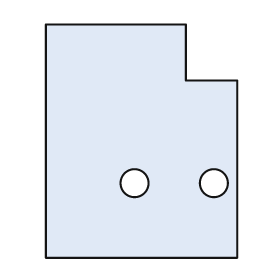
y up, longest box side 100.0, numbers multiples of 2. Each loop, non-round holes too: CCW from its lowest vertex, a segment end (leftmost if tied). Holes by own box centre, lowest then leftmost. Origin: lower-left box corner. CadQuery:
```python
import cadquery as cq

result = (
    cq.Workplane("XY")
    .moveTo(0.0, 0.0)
    .lineTo(82.0, 0.0)
    .lineTo(82.0, 76.0)
    .lineTo(60.0, 76.0)
    .lineTo(60.0, 100.0)
    .lineTo(0.0, 100.0)
    .close()
    .moveTo(38.0, 32.0)
    .circle(6.0)
    .moveTo(72.0, 32.0)
    .circle(6.0)
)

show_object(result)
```